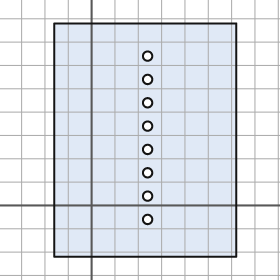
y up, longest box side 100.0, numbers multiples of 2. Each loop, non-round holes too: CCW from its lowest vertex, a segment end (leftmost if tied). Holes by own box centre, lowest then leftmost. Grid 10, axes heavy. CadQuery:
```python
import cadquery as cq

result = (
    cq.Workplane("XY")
    .moveTo(-16.0, -22.0)
    .lineTo(62.0, -22.0)
    .lineTo(62.0, 78.0)
    .lineTo(-16.0, 78.0)
    .close()
    .moveTo(24.0, -6.0)
    .circle(2.0)
    .moveTo(24.0, 4.0)
    .circle(2.0)
    .moveTo(24.0, 14.0)
    .circle(2.0)
    .moveTo(24.0, 24.0)
    .circle(2.0)
    .moveTo(24.0, 34.0)
    .circle(2.0)
    .moveTo(24.0, 44.0)
    .circle(2.0)
    .moveTo(24.0, 54.0)
    .circle(2.0)
    .moveTo(24.0, 64.0)
    .circle(2.0)
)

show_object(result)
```